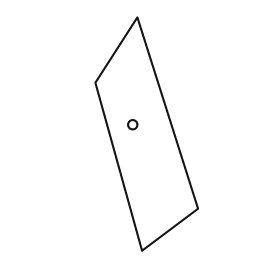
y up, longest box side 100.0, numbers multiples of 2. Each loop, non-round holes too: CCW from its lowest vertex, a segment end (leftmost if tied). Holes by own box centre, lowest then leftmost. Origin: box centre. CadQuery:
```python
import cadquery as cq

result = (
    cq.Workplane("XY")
    .moveTo(-2.0, -50.0)
    .lineTo(22.0, -32.0)
    .lineTo(-4.0, 50.0)
    .lineTo(-22.0, 22.0)
    .close()
    .moveTo(-6.0, 4.0)
    .circle(2.0)
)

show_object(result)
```